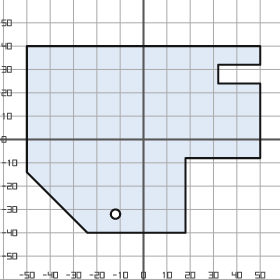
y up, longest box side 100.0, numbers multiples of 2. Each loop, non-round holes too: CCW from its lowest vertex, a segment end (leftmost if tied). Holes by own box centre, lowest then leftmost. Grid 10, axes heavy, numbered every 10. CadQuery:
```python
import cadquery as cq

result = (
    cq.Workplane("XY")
    .moveTo(-24.0, -40.0)
    .lineTo(18.0, -40.0)
    .lineTo(18.0, -8.0)
    .lineTo(50.0, -8.0)
    .lineTo(50.0, 24.0)
    .lineTo(32.0, 24.0)
    .lineTo(32.0, 32.0)
    .lineTo(50.0, 32.0)
    .lineTo(50.0, 40.0)
    .lineTo(-50.0, 40.0)
    .lineTo(-50.0, -14.0)
    .close()
    .moveTo(-12.0, -32.0)
    .circle(2.0)
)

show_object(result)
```